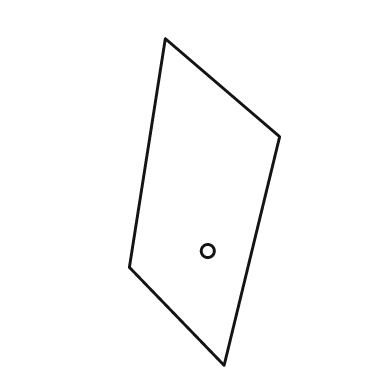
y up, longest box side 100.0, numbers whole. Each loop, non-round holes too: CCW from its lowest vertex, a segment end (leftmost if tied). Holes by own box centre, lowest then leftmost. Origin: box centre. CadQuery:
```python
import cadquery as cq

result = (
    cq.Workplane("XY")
    .moveTo(6.0, -50.0)
    .lineTo(23.0, 20.0)
    .lineTo(-12.0, 50.0)
    .lineTo(-23.0, -20.0)
    .close()
    .moveTo(1.0, -15.0)
    .circle(2.0)
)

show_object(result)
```